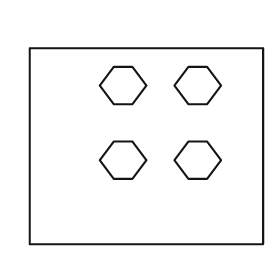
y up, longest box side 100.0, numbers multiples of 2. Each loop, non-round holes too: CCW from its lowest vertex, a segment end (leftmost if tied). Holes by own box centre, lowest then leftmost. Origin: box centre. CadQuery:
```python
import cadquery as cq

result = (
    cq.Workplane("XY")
    .moveTo(-50.0, -42.0)
    .lineTo(50.0, -42.0)
    .lineTo(50.0, 42.0)
    .lineTo(-50.0, 42.0)
    .close()
    .moveTo(-14.0, -14.0)
    .lineTo(-6.0, -14.0)
    .lineTo(0.0, -6.0)
    .lineTo(-6.0, 2.0)
    .lineTo(-14.0, 2.0)
    .lineTo(-20.0, -6.0)
    .close()
    .moveTo(18.0, -14.0)
    .lineTo(26.0, -14.0)
    .lineTo(32.0, -6.0)
    .lineTo(26.0, 2.0)
    .lineTo(18.0, 2.0)
    .lineTo(12.0, -6.0)
    .close()
    .moveTo(-14.0, 18.0)
    .lineTo(-6.0, 18.0)
    .lineTo(0.0, 26.0)
    .lineTo(-6.0, 34.0)
    .lineTo(-14.0, 34.0)
    .lineTo(-20.0, 26.0)
    .close()
    .moveTo(18.0, 18.0)
    .lineTo(26.0, 18.0)
    .lineTo(32.0, 26.0)
    .lineTo(26.0, 34.0)
    .lineTo(18.0, 34.0)
    .lineTo(12.0, 26.0)
    .close()
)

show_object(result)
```